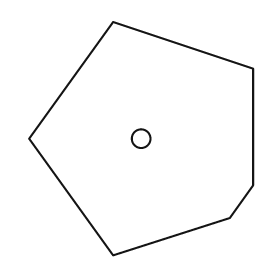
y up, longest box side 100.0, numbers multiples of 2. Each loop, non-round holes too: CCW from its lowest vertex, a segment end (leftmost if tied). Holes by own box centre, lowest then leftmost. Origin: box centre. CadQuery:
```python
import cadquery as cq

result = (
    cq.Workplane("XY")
    .moveTo(-12.0, -50.0)
    .lineTo(38.0, -34.0)
    .lineTo(48.0, -20.0)
    .lineTo(48.0, 30.0)
    .lineTo(-12.0, 50.0)
    .lineTo(-48.0, 0.0)
    .close()
    .moveTo(0.0, 0.0)
    .circle(4.0)
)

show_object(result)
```